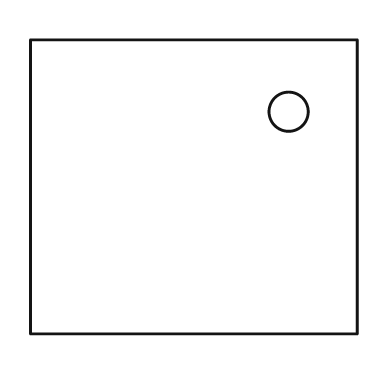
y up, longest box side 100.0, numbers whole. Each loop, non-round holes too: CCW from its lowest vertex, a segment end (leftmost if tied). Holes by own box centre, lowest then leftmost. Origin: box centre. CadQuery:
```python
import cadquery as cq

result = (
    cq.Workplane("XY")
    .moveTo(-50.0, -45.0)
    .lineTo(50.0, -45.0)
    .lineTo(50.0, 45.0)
    .lineTo(-50.0, 45.0)
    .close()
    .moveTo(29.0, 23.0)
    .circle(6.0)
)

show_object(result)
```